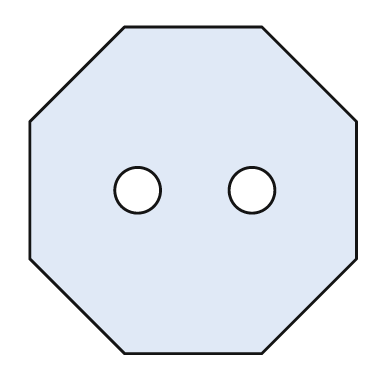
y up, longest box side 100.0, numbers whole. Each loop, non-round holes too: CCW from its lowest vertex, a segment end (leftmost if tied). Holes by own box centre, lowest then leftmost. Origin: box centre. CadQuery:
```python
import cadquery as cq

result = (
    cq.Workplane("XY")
    .moveTo(-21.0, -50.0)
    .lineTo(21.0, -50.0)
    .lineTo(50.0, -21.0)
    .lineTo(50.0, 21.0)
    .lineTo(21.0, 50.0)
    .lineTo(-21.0, 50.0)
    .lineTo(-50.0, 21.0)
    .lineTo(-50.0, -21.0)
    .close()
    .moveTo(-17.0, 0.0)
    .circle(7.0)
    .moveTo(18.0, 0.0)
    .circle(7.0)
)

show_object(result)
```